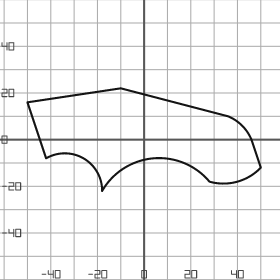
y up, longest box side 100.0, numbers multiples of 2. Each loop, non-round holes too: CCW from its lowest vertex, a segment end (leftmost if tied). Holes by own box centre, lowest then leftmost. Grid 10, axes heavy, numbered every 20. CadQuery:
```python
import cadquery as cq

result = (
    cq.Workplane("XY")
    .moveTo(-18.0, -22.0)
    .threePointArc((4.0, -8.0), (28.0, -18.0))
    .threePointArc((40.0, -18.0), (50.0, -12.0))
    .lineTo(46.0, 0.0)
    .threePointArc((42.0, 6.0), (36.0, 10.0))
    .lineTo(-10.0, 22.0)
    .lineTo(-50.0, 16.0)
    .lineTo(-42.0, -8.0)
    .threePointArc((-26.0, -8.0), (-18.0, -22.0))
    .close()
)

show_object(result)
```